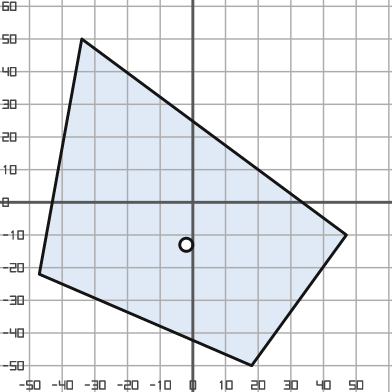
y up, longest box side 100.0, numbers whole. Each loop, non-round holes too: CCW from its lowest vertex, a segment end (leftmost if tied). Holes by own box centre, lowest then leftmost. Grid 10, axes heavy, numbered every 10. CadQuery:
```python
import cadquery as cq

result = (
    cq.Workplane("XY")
    .moveTo(18.0, -50.0)
    .lineTo(47.0, -10.0)
    .lineTo(-34.0, 50.0)
    .lineTo(-47.0, -22.0)
    .close()
    .moveTo(-2.0, -13.0)
    .circle(2.0)
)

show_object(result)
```